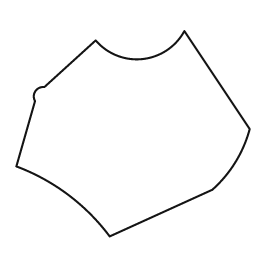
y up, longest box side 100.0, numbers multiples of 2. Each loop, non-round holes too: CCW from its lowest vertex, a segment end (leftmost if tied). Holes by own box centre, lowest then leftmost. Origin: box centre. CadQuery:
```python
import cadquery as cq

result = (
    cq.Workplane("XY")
    .moveTo(-10.0, -44.0)
    .lineTo(34.0, -24.0)
    .threePointArc((44.0, -12.0), (50.0, 2.0))
    .lineTo(22.0, 44.0)
    .threePointArc((4.0, 32.0), (-16.0, 40.0))
    .lineTo(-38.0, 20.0)
    .threePointArc((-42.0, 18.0), (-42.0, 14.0))
    .lineTo(-50.0, -14.0)
    .threePointArc((-28.0, -26.0), (-10.0, -44.0))
    .close()
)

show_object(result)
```